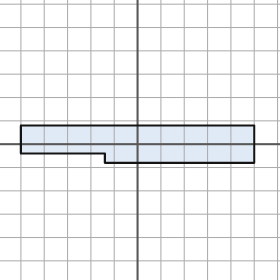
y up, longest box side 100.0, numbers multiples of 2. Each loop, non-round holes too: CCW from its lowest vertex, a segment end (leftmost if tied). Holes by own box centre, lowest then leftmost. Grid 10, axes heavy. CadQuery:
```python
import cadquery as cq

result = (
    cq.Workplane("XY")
    .moveTo(-14.0, -8.0)
    .lineTo(50.0, -8.0)
    .lineTo(50.0, 8.0)
    .lineTo(-50.0, 8.0)
    .lineTo(-50.0, -4.0)
    .lineTo(-14.0, -4.0)
    .close()
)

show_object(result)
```